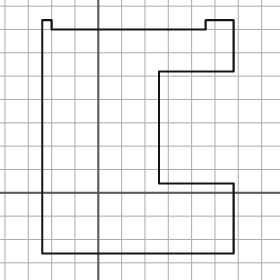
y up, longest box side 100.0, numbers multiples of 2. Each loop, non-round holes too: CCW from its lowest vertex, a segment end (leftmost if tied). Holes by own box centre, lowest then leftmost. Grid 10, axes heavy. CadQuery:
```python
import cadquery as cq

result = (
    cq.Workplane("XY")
    .moveTo(-24.0, -26.0)
    .lineTo(58.0, -26.0)
    .lineTo(58.0, 4.0)
    .lineTo(26.0, 4.0)
    .lineTo(26.0, 52.0)
    .lineTo(58.0, 52.0)
    .lineTo(58.0, 74.0)
    .lineTo(46.0, 74.0)
    .lineTo(46.0, 70.0)
    .lineTo(-20.0, 70.0)
    .lineTo(-20.0, 74.0)
    .lineTo(-24.0, 74.0)
    .close()
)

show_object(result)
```